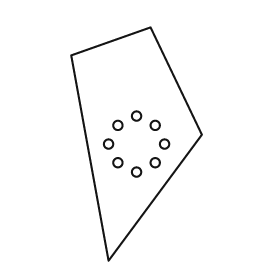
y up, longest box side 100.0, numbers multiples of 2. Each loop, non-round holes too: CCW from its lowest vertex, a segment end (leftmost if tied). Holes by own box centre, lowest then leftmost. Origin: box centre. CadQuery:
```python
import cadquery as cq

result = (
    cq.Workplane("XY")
    .moveTo(-12.0, -50.0)
    .lineTo(28.0, 4.0)
    .lineTo(6.0, 50.0)
    .lineTo(-28.0, 38.0)
    .close()
    .moveTo(0.0, -12.0)
    .circle(2.0)
    .moveTo(-8.0, -8.0)
    .circle(2.0)
    .moveTo(8.0, -8.0)
    .circle(2.0)
    .moveTo(-12.0, 0.0)
    .circle(2.0)
    .moveTo(12.0, 0.0)
    .circle(2.0)
    .moveTo(-8.0, 8.0)
    .circle(2.0)
    .moveTo(8.0, 8.0)
    .circle(2.0)
    .moveTo(0.0, 12.0)
    .circle(2.0)
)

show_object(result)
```